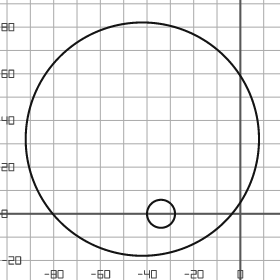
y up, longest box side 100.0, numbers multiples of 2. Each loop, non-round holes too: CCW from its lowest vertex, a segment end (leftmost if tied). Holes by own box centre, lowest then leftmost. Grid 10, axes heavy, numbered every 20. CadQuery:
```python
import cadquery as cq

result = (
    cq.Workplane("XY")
    .moveTo(-42.0, 32.0)
    .circle(50.0)
    .moveTo(-34.0, 0.0)
    .circle(6.0)
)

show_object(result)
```